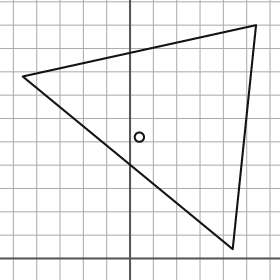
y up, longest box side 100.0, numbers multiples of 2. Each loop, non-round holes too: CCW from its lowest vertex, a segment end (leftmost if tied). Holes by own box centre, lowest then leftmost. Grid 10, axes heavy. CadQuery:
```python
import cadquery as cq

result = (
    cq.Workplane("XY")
    .moveTo(44.0, 4.0)
    .lineTo(54.0, 100.0)
    .lineTo(-46.0, 78.0)
    .close()
    .moveTo(4.0, 52.0)
    .circle(2.0)
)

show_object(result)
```